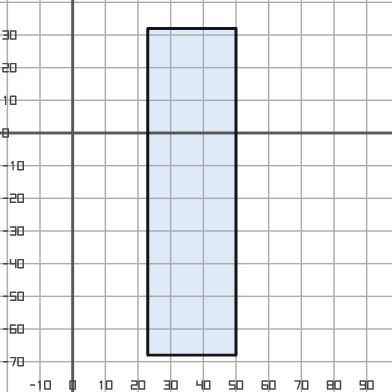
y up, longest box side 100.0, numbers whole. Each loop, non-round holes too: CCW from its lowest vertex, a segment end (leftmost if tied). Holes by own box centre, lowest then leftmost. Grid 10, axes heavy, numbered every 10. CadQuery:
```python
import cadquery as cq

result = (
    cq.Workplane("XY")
    .moveTo(23.0, -68.0)
    .lineTo(50.0, -68.0)
    .lineTo(50.0, 32.0)
    .lineTo(23.0, 32.0)
    .close()
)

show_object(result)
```